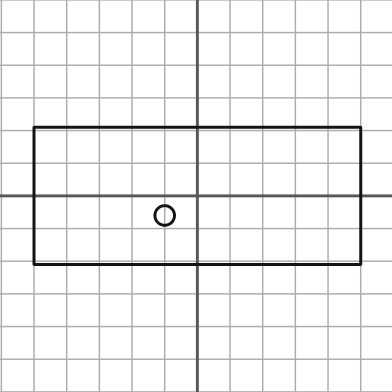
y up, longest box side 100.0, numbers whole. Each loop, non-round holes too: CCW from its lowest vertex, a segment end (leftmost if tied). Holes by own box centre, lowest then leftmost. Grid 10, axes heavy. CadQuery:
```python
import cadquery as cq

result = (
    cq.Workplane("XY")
    .moveTo(-50.0, -21.0)
    .lineTo(50.0, -21.0)
    .lineTo(50.0, 21.0)
    .lineTo(-50.0, 21.0)
    .close()
    .moveTo(-10.0, -6.0)
    .circle(3.0)
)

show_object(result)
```